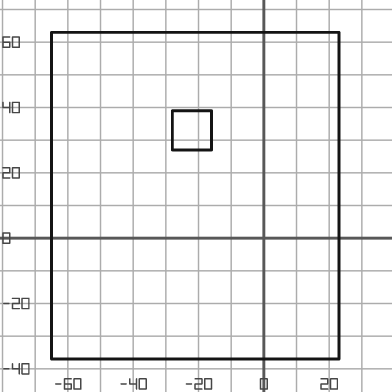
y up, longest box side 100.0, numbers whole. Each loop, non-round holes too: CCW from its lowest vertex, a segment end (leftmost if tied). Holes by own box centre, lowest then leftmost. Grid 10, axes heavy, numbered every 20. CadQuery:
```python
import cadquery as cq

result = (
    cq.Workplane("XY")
    .moveTo(-65.0, -37.0)
    .lineTo(23.0, -37.0)
    .lineTo(23.0, 63.0)
    .lineTo(-65.0, 63.0)
    .close()
    .moveTo(-28.0, 27.0)
    .lineTo(-16.0, 27.0)
    .lineTo(-16.0, 39.0)
    .lineTo(-28.0, 39.0)
    .close()
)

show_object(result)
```